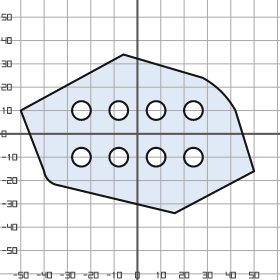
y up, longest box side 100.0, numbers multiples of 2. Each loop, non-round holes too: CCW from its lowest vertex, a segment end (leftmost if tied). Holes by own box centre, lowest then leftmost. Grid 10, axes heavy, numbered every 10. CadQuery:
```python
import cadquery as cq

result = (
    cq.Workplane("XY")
    .moveTo(16.0, -34.0)
    .lineTo(50.0, -16.0)
    .lineTo(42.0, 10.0)
    .threePointArc((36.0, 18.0), (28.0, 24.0))
    .lineTo(-6.0, 34.0)
    .lineTo(-50.0, 10.0)
    .lineTo(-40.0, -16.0)
    .threePointArc((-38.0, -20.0), (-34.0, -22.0))
    .close()
    .moveTo(-24.0, -10.0)
    .circle(4.0)
    .moveTo(-8.0, -10.0)
    .circle(4.0)
    .moveTo(8.0, -10.0)
    .circle(4.0)
    .moveTo(24.0, -10.0)
    .circle(4.0)
    .moveTo(-24.0, 10.0)
    .circle(4.0)
    .moveTo(-8.0, 10.0)
    .circle(4.0)
    .moveTo(8.0, 10.0)
    .circle(4.0)
    .moveTo(24.0, 10.0)
    .circle(4.0)
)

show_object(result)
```